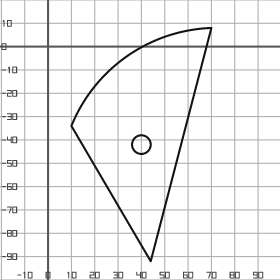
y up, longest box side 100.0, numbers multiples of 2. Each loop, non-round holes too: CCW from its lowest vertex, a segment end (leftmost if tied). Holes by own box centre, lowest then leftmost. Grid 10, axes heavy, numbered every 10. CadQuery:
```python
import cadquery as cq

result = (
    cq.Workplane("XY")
    .moveTo(44.0, -92.0)
    .lineTo(70.0, 8.0)
    .threePointArc((34.0, -4.0), (10.0, -34.0))
    .close()
    .moveTo(40.0, -42.0)
    .circle(4.0)
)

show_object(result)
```